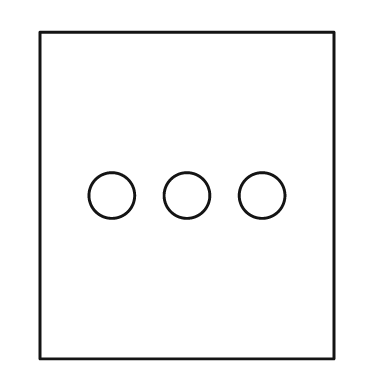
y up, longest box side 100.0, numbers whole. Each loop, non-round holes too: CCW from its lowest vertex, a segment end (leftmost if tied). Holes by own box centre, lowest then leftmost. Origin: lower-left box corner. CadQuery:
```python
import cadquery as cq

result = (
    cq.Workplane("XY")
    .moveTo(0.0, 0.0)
    .lineTo(90.0, 0.0)
    .lineTo(90.0, 100.0)
    .lineTo(0.0, 100.0)
    .close()
    .moveTo(22.0, 50.0)
    .circle(7.0)
    .moveTo(45.0, 50.0)
    .circle(7.0)
    .moveTo(68.0, 50.0)
    .circle(7.0)
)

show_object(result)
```